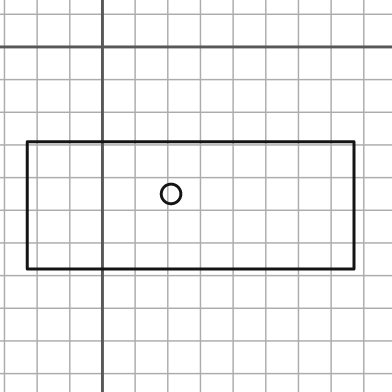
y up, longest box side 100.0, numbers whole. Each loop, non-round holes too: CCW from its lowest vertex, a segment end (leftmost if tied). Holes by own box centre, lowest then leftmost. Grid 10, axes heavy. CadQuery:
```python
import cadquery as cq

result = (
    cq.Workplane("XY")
    .moveTo(-23.0, -68.0)
    .lineTo(77.0, -68.0)
    .lineTo(77.0, -29.0)
    .lineTo(-23.0, -29.0)
    .close()
    .moveTo(21.0, -45.0)
    .circle(3.0)
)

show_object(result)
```